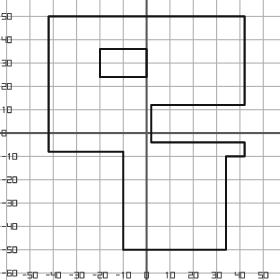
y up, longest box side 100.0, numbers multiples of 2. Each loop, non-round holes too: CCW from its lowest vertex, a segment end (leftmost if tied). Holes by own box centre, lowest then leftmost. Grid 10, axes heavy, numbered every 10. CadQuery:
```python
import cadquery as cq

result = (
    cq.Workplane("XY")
    .moveTo(-10.0, -50.0)
    .lineTo(34.0, -50.0)
    .lineTo(34.0, -10.0)
    .lineTo(42.0, -10.0)
    .lineTo(42.0, -4.0)
    .lineTo(2.0, -4.0)
    .lineTo(2.0, 12.0)
    .lineTo(42.0, 12.0)
    .lineTo(42.0, 50.0)
    .lineTo(-42.0, 50.0)
    .lineTo(-42.0, -8.0)
    .lineTo(-10.0, -8.0)
    .close()
    .moveTo(-20.0, 24.0)
    .lineTo(0.0, 24.0)
    .lineTo(0.0, 36.0)
    .lineTo(-20.0, 36.0)
    .close()
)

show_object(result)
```